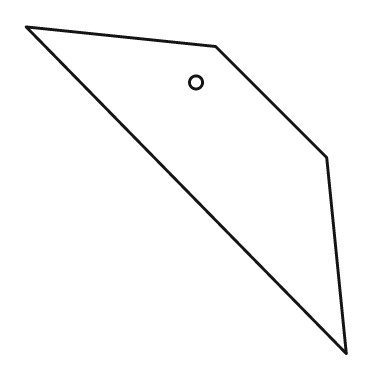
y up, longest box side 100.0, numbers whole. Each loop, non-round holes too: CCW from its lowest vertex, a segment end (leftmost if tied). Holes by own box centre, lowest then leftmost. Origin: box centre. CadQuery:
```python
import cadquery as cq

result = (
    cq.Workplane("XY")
    .moveTo(49.0, -50.0)
    .lineTo(43.0, 10.0)
    .lineTo(9.0, 44.0)
    .lineTo(-49.0, 50.0)
    .close()
    .moveTo(3.0, 33.0)
    .circle(2.0)
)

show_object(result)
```